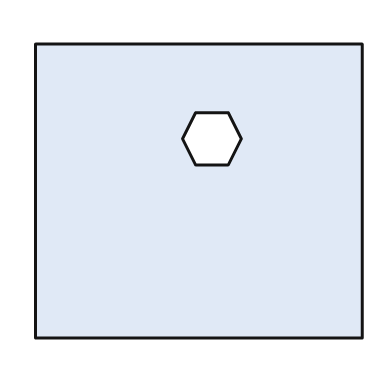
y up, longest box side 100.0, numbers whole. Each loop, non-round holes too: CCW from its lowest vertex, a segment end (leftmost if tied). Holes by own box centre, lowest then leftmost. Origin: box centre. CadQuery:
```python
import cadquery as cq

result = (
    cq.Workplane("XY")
    .moveTo(-50.0, -45.0)
    .lineTo(50.0, -45.0)
    .lineTo(50.0, 45.0)
    .lineTo(-50.0, 45.0)
    .close()
    .moveTo(-1.0, 8.0)
    .lineTo(9.0, 8.0)
    .lineTo(13.0, 16.0)
    .lineTo(9.0, 24.0)
    .lineTo(-1.0, 24.0)
    .lineTo(-5.0, 16.0)
    .close()
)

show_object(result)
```